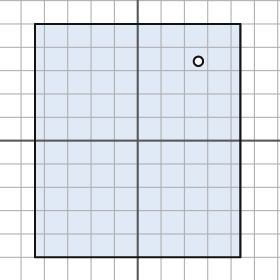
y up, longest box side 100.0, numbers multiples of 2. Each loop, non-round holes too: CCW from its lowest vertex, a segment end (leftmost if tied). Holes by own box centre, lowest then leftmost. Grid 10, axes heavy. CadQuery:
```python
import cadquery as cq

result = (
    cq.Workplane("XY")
    .moveTo(-44.0, -50.0)
    .lineTo(44.0, -50.0)
    .lineTo(44.0, 50.0)
    .lineTo(-44.0, 50.0)
    .close()
    .moveTo(26.0, 34.0)
    .circle(2.0)
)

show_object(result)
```